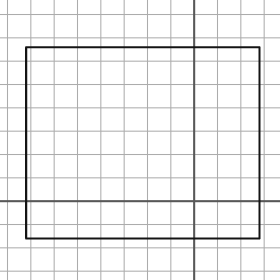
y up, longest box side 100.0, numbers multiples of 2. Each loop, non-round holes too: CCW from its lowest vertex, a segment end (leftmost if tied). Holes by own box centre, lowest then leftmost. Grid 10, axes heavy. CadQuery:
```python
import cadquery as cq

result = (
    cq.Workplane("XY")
    .moveTo(-72.0, -16.0)
    .lineTo(28.0, -16.0)
    .lineTo(28.0, 66.0)
    .lineTo(-72.0, 66.0)
    .close()
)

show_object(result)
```